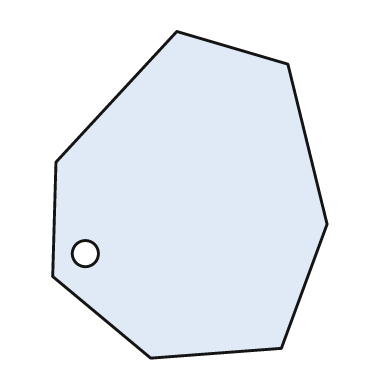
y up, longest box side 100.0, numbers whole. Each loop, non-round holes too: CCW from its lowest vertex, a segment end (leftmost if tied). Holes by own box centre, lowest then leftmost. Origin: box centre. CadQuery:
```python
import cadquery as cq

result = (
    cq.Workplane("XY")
    .moveTo(-12.0, -50.0)
    .lineTo(28.0, -47.0)
    .lineTo(42.0, -9.0)
    .lineTo(30.0, 40.0)
    .lineTo(-4.0, 50.0)
    .lineTo(-41.0, 10.0)
    .lineTo(-42.0, -25.0)
    .close()
    .moveTo(-32.0, -18.0)
    .circle(4.0)
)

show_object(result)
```